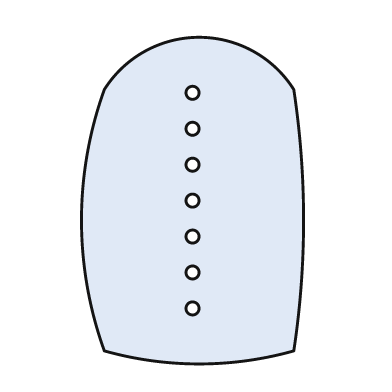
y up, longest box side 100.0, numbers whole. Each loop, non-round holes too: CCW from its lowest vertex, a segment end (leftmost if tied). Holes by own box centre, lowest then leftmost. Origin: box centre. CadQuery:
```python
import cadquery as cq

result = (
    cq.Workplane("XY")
    .moveTo(-27.0, -46.0)
    .threePointArc((2.0, -50.0), (31.0, -46.0))
    .threePointArc((34.0, -6.0), (31.0, 34.0))
    .threePointArc((2.0, 50.0), (-27.0, 34.0))
    .threePointArc((-34.0, -6.0), (-27.0, -46.0))
    .close()
    .moveTo(0.0, -33.0)
    .circle(2.0)
    .moveTo(0.0, -22.0)
    .circle(2.0)
    .moveTo(0.0, -11.0)
    .circle(2.0)
    .moveTo(0.0, 0.0)
    .circle(2.0)
    .moveTo(0.0, 11.0)
    .circle(2.0)
    .moveTo(0.0, 22.0)
    .circle(2.0)
    .moveTo(0.0, 33.0)
    .circle(2.0)
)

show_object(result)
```